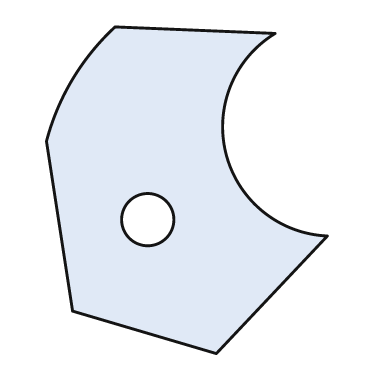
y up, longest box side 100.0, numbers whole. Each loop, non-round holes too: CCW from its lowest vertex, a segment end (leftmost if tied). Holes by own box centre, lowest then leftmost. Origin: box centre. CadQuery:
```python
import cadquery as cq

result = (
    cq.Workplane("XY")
    .moveTo(9.0, -50.0)
    .lineTo(43.0, -14.0)
    .threePointArc((12.0, 11.0), (27.0, 48.0))
    .lineTo(-22.0, 50.0)
    .threePointArc((-35.0, 34.0), (-43.0, 15.0))
    .lineTo(-35.0, -37.0)
    .close()
    .moveTo(-12.0, -9.0)
    .circle(8.0)
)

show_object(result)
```